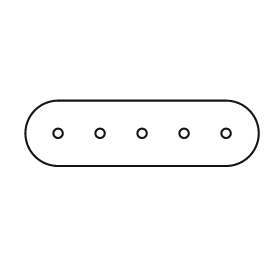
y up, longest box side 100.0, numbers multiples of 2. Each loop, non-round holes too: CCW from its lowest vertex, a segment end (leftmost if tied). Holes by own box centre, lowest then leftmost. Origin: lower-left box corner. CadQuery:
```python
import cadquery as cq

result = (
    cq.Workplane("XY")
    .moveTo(14.0, 0.0)
    .lineTo(86.0, 0.0)
    .threePointArc((100.0, 14.0), (86.0, 28.0))
    .lineTo(14.0, 28.0)
    .threePointArc((0.0, 14.0), (14.0, 0.0))
    .close()
    .moveTo(14.0, 14.0)
    .circle(2.0)
    .moveTo(32.0, 14.0)
    .circle(2.0)
    .moveTo(50.0, 14.0)
    .circle(2.0)
    .moveTo(68.0, 14.0)
    .circle(2.0)
    .moveTo(86.0, 14.0)
    .circle(2.0)
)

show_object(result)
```